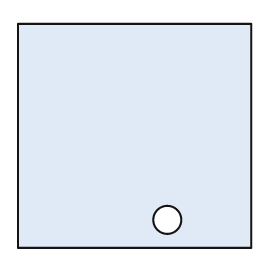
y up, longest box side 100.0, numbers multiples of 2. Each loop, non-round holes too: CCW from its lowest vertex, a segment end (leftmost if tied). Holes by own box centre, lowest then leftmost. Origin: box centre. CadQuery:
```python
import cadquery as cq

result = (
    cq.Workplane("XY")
    .moveTo(-50.0, -48.0)
    .lineTo(50.0, -48.0)
    .lineTo(50.0, 48.0)
    .lineTo(-50.0, 48.0)
    .close()
    .moveTo(14.0, -36.0)
    .circle(6.0)
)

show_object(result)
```